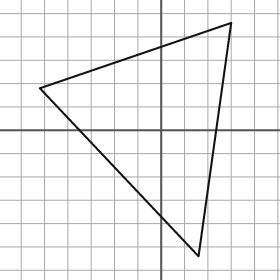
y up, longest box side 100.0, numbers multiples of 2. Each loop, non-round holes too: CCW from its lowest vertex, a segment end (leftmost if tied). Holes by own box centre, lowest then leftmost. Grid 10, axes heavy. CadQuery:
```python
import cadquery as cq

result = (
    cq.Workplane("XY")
    .moveTo(16.0, -54.0)
    .lineTo(30.0, 46.0)
    .lineTo(-52.0, 18.0)
    .close()
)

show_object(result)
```